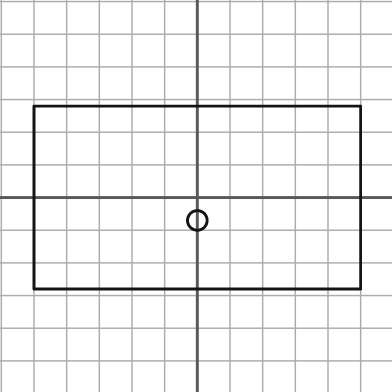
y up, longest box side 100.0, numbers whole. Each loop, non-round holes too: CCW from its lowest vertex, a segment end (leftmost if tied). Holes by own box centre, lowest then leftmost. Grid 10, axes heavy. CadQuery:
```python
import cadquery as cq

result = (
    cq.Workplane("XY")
    .moveTo(-50.0, -28.0)
    .lineTo(50.0, -28.0)
    .lineTo(50.0, 28.0)
    .lineTo(-50.0, 28.0)
    .close()
    .moveTo(0.0, -7.0)
    .circle(3.0)
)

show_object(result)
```